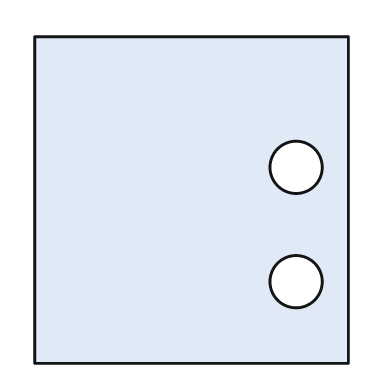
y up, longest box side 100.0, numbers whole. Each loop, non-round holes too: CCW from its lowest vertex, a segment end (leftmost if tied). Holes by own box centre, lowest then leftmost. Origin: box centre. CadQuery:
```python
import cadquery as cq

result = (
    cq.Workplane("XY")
    .moveTo(-48.0, -50.0)
    .lineTo(48.0, -50.0)
    .lineTo(48.0, 50.0)
    .lineTo(-48.0, 50.0)
    .close()
    .moveTo(32.0, -25.0)
    .circle(8.0)
    .moveTo(32.0, 10.0)
    .circle(8.0)
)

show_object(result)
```